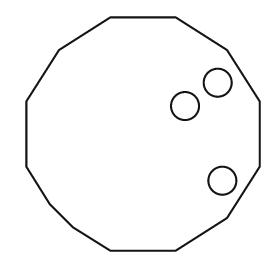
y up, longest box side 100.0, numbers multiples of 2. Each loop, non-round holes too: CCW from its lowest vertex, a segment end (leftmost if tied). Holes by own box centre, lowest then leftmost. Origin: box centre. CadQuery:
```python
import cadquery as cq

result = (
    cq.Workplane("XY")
    .moveTo(-14.0, -50.0)
    .lineTo(14.0, -50.0)
    .lineTo(36.0, -36.0)
    .lineTo(50.0, -14.0)
    .lineTo(50.0, 14.0)
    .lineTo(36.0, 36.0)
    .lineTo(14.0, 50.0)
    .lineTo(-14.0, 50.0)
    .lineTo(-36.0, 36.0)
    .lineTo(-50.0, 14.0)
    .lineTo(-50.0, -14.0)
    .lineTo(-40.0, -30.0)
    .lineTo(-30.0, -40.0)
    .close()
    .moveTo(34.0, -20.0)
    .circle(6.0)
    .moveTo(18.0, 12.0)
    .circle(6.0)
    .moveTo(32.0, 22.0)
    .circle(6.0)
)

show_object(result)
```